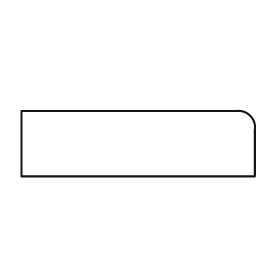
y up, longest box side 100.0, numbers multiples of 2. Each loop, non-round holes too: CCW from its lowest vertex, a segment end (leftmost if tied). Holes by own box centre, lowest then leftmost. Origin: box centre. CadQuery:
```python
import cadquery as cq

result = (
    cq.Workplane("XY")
    .moveTo(-50.0, -14.0)
    .lineTo(50.0, -14.0)
    .lineTo(50.0, 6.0)
    .threePointArc((48.0, 12.0), (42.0, 14.0))
    .lineTo(-50.0, 14.0)
    .close()
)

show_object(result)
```